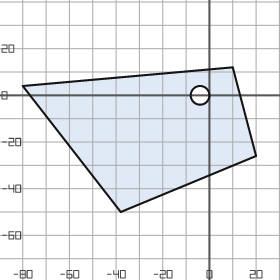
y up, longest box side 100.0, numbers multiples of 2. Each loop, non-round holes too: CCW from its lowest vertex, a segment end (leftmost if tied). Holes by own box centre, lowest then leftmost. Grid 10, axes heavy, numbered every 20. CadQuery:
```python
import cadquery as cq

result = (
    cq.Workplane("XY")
    .moveTo(-38.0, -50.0)
    .lineTo(20.0, -26.0)
    .lineTo(10.0, 12.0)
    .lineTo(-80.0, 4.0)
    .close()
    .moveTo(-4.0, 0.0)
    .circle(4.0)
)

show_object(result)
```